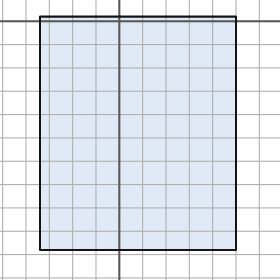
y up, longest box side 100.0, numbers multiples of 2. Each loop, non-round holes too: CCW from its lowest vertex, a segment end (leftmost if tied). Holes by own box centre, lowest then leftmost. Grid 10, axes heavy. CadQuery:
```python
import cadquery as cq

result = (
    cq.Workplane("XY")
    .moveTo(-34.0, -98.0)
    .lineTo(50.0, -98.0)
    .lineTo(50.0, 2.0)
    .lineTo(-34.0, 2.0)
    .close()
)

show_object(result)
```